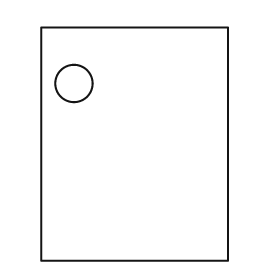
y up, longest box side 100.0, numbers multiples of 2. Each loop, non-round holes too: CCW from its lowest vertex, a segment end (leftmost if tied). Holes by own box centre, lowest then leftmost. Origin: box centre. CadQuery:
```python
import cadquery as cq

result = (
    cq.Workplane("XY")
    .moveTo(-40.0, -50.0)
    .lineTo(40.0, -50.0)
    .lineTo(40.0, 50.0)
    .lineTo(-40.0, 50.0)
    .close()
    .moveTo(-26.0, 26.0)
    .circle(8.0)
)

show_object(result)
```